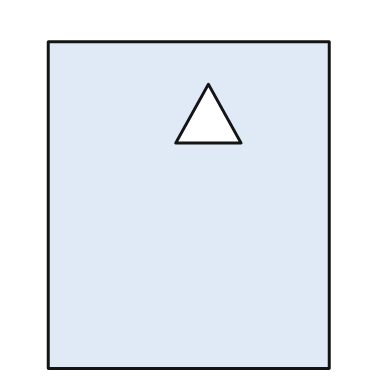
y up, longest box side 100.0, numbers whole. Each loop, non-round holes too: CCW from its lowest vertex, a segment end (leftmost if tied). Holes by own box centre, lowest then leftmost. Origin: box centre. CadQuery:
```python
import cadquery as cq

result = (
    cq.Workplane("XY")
    .moveTo(-43.0, -50.0)
    .lineTo(43.0, -50.0)
    .lineTo(43.0, 50.0)
    .lineTo(-43.0, 50.0)
    .close()
    .moveTo(-4.0, 19.0)
    .lineTo(16.0, 19.0)
    .lineTo(6.0, 37.0)
    .close()
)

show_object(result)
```